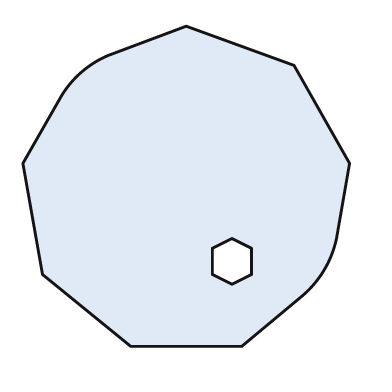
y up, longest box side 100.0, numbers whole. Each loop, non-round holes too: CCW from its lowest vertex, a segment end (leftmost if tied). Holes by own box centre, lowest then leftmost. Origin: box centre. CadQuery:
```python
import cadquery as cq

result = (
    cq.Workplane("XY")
    .moveTo(-17.0, -49.0)
    .lineTo(17.0, -49.0)
    .lineTo(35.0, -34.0)
    .threePointArc((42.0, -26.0), (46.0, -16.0))
    .lineTo(50.0, 7.0)
    .lineTo(33.0, 37.0)
    .lineTo(0.0, 49.0)
    .lineTo(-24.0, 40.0)
    .threePointArc((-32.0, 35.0), (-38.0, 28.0))
    .lineTo(-50.0, 7.0)
    .lineTo(-44.0, -27.0)
    .close()
    .moveTo(14.0, -30.0)
    .lineTo(20.0, -27.0)
    .lineTo(20.0, -19.0)
    .lineTo(14.0, -16.0)
    .lineTo(8.0, -19.0)
    .lineTo(8.0, -27.0)
    .close()
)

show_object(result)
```